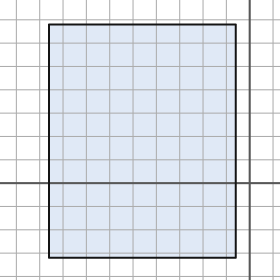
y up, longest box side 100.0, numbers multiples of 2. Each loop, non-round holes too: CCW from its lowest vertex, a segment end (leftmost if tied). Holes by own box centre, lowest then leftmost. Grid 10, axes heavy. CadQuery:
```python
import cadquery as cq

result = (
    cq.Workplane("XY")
    .moveTo(-86.0, -32.0)
    .lineTo(-6.0, -32.0)
    .lineTo(-6.0, 68.0)
    .lineTo(-86.0, 68.0)
    .close()
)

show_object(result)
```